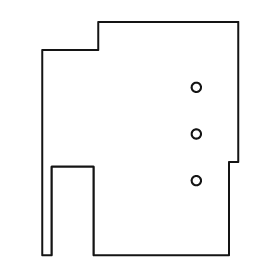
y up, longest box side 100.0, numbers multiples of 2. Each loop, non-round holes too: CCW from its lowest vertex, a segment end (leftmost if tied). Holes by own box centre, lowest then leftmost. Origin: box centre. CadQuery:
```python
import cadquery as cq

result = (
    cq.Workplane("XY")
    .moveTo(-42.0, -50.0)
    .lineTo(-38.0, -50.0)
    .lineTo(-38.0, -12.0)
    .lineTo(-20.0, -12.0)
    .lineTo(-20.0, -50.0)
    .lineTo(38.0, -50.0)
    .lineTo(38.0, -10.0)
    .lineTo(42.0, -10.0)
    .lineTo(42.0, 50.0)
    .lineTo(-18.0, 50.0)
    .lineTo(-18.0, 38.0)
    .lineTo(-42.0, 38.0)
    .close()
    .moveTo(24.0, -18.0)
    .circle(2.0)
    .moveTo(24.0, 2.0)
    .circle(2.0)
    .moveTo(24.0, 22.0)
    .circle(2.0)
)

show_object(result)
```